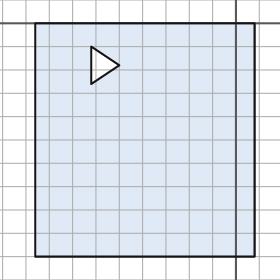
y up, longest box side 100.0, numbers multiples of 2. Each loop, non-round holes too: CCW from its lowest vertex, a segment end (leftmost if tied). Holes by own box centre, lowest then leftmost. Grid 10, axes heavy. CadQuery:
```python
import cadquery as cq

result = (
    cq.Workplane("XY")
    .moveTo(-86.0, -100.0)
    .lineTo(8.0, -100.0)
    .lineTo(8.0, 0.0)
    .lineTo(-86.0, 0.0)
    .close()
    .moveTo(-62.0, -26.0)
    .lineTo(-50.0, -18.0)
    .lineTo(-62.0, -10.0)
    .close()
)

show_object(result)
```